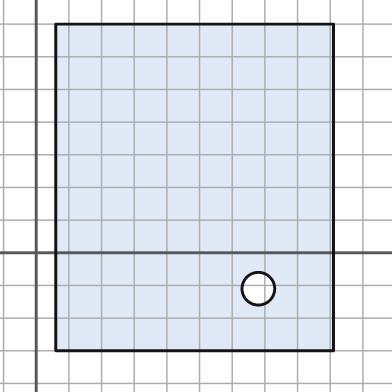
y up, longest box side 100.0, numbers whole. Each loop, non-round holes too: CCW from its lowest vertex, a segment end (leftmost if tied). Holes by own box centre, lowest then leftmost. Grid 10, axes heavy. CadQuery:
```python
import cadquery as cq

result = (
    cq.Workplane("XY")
    .moveTo(6.0, -30.0)
    .lineTo(91.0, -30.0)
    .lineTo(91.0, 70.0)
    .lineTo(6.0, 70.0)
    .close()
    .moveTo(68.0, -11.0)
    .circle(5.0)
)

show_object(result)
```